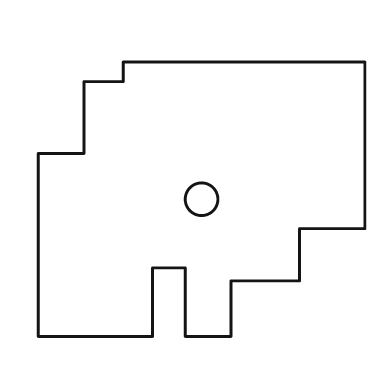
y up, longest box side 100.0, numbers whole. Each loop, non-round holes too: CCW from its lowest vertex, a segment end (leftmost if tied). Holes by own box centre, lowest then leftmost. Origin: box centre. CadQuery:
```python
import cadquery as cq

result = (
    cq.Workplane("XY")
    .moveTo(-50.0, -42.0)
    .lineTo(-15.0, -42.0)
    .lineTo(-15.0, -21.0)
    .lineTo(-5.0, -21.0)
    .lineTo(-5.0, -42.0)
    .lineTo(9.0, -42.0)
    .lineTo(9.0, -25.0)
    .lineTo(30.0, -25.0)
    .lineTo(30.0, -9.0)
    .lineTo(50.0, -9.0)
    .lineTo(50.0, 42.0)
    .lineTo(-24.0, 42.0)
    .lineTo(-24.0, 36.0)
    .lineTo(-36.0, 36.0)
    .lineTo(-36.0, 14.0)
    .lineTo(-50.0, 14.0)
    .close()
    .moveTo(0.0, 0.0)
    .circle(5.0)
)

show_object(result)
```